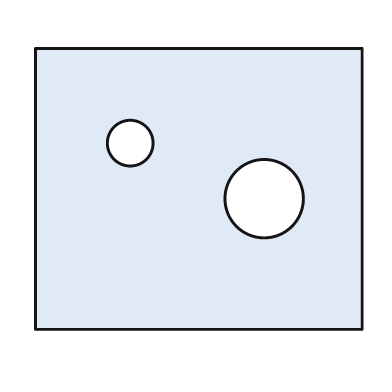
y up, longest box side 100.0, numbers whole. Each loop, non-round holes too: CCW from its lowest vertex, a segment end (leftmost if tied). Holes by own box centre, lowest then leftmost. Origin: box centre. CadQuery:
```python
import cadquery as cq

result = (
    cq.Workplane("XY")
    .moveTo(-50.0, -43.0)
    .lineTo(50.0, -43.0)
    .lineTo(50.0, 43.0)
    .lineTo(-50.0, 43.0)
    .close()
    .moveTo(20.0, -3.0)
    .circle(12.0)
    .moveTo(-21.0, 14.0)
    .circle(7.0)
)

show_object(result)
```